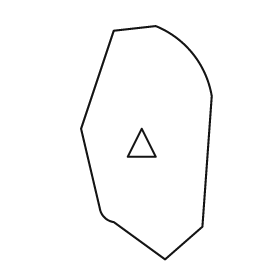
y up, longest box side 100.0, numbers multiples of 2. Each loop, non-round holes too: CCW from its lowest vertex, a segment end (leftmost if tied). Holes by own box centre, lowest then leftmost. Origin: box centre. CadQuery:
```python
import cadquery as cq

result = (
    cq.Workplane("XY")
    .moveTo(8.0, -50.0)
    .lineTo(24.0, -36.0)
    .lineTo(28.0, 20.0)
    .threePointArc((20.0, 38.0), (4.0, 50.0))
    .lineTo(-14.0, 48.0)
    .lineTo(-28.0, 6.0)
    .lineTo(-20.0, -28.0)
    .threePointArc((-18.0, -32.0), (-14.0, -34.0))
    .close()
    .moveTo(-8.0, -6.0)
    .lineTo(4.0, -6.0)
    .lineTo(-2.0, 6.0)
    .close()
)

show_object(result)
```